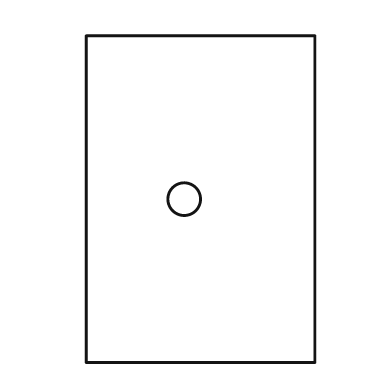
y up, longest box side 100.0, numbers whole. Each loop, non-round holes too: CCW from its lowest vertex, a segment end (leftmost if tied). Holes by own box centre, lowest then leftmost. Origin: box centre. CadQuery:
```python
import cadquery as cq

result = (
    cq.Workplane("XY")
    .moveTo(-35.0, -50.0)
    .lineTo(35.0, -50.0)
    .lineTo(35.0, 50.0)
    .lineTo(-35.0, 50.0)
    .close()
    .moveTo(-5.0, 0.0)
    .circle(5.0)
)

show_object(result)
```